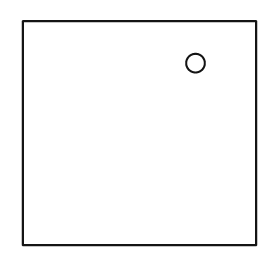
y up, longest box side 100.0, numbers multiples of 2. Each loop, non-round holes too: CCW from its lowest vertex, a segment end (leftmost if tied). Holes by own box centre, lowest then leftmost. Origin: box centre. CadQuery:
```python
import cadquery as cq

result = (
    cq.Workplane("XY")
    .moveTo(-50.0, -48.0)
    .lineTo(50.0, -48.0)
    .lineTo(50.0, 48.0)
    .lineTo(-50.0, 48.0)
    .close()
    .moveTo(24.0, 30.0)
    .circle(4.0)
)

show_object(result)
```